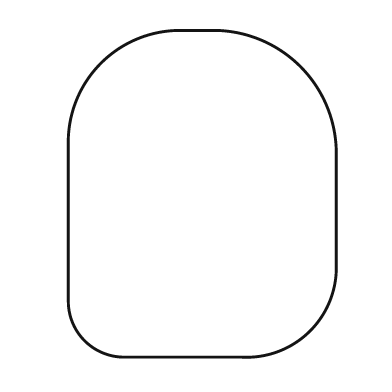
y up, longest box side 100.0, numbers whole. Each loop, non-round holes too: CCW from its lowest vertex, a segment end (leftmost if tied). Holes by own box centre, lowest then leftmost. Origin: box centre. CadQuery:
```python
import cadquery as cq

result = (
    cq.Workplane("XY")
    .moveTo(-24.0, -50.0)
    .lineTo(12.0, -50.0)
    .threePointArc((33.0, -42.0), (41.0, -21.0))
    .lineTo(41.0, 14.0)
    .threePointArc((30.0, 39.0), (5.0, 50.0))
    .lineTo(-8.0, 50.0)
    .threePointArc((-31.0, 40.0), (-41.0, 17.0))
    .lineTo(-41.0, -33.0)
    .threePointArc((-36.0, -45.0), (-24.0, -50.0))
    .close()
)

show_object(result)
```